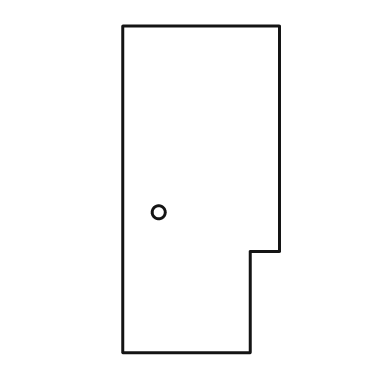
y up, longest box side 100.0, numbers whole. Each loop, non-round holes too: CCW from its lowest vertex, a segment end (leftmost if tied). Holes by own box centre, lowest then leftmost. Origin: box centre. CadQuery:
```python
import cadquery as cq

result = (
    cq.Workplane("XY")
    .moveTo(-24.0, -50.0)
    .lineTo(15.0, -50.0)
    .lineTo(15.0, -19.0)
    .lineTo(24.0, -19.0)
    .lineTo(24.0, 50.0)
    .lineTo(-24.0, 50.0)
    .close()
    .moveTo(-13.0, -7.0)
    .circle(2.0)
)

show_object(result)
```